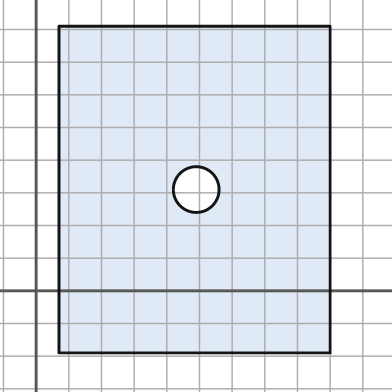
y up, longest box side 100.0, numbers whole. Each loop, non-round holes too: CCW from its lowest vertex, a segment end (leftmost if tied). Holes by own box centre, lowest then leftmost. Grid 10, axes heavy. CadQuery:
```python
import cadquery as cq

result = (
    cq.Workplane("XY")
    .moveTo(7.0, -19.0)
    .lineTo(90.0, -19.0)
    .lineTo(90.0, 81.0)
    .lineTo(7.0, 81.0)
    .close()
    .moveTo(49.0, 31.0)
    .circle(7.0)
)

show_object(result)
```